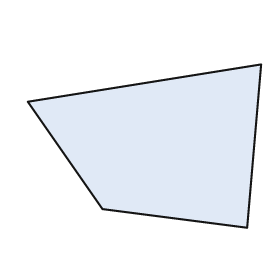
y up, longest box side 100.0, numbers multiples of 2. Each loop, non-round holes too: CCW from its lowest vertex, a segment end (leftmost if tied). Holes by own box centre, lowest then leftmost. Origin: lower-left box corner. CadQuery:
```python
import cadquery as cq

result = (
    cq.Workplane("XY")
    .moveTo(94.0, 0.0)
    .lineTo(100.0, 70.0)
    .lineTo(0.0, 54.0)
    .lineTo(32.0, 8.0)
    .close()
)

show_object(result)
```